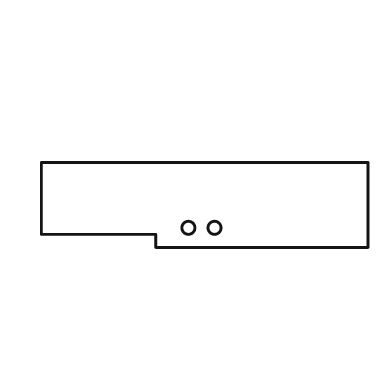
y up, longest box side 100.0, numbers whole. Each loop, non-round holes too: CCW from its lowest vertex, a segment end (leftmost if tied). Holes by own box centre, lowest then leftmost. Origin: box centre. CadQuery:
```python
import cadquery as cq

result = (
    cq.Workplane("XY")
    .moveTo(-15.0, -13.0)
    .lineTo(50.0, -13.0)
    .lineTo(50.0, 13.0)
    .lineTo(-50.0, 13.0)
    .lineTo(-50.0, -9.0)
    .lineTo(-15.0, -9.0)
    .close()
    .moveTo(-5.0, -7.0)
    .circle(2.0)
    .moveTo(3.0, -7.0)
    .circle(2.0)
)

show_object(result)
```